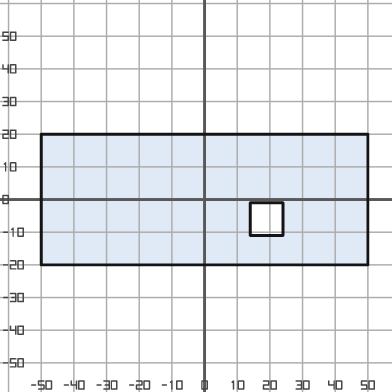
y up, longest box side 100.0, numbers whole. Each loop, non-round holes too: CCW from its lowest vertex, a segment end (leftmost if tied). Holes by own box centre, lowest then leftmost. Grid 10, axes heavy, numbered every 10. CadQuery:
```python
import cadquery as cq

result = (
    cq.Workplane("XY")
    .moveTo(-50.0, -20.0)
    .lineTo(50.0, -20.0)
    .lineTo(50.0, 20.0)
    .lineTo(-50.0, 20.0)
    .close()
    .moveTo(14.0, -11.0)
    .lineTo(24.0, -11.0)
    .lineTo(24.0, -1.0)
    .lineTo(14.0, -1.0)
    .close()
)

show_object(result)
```